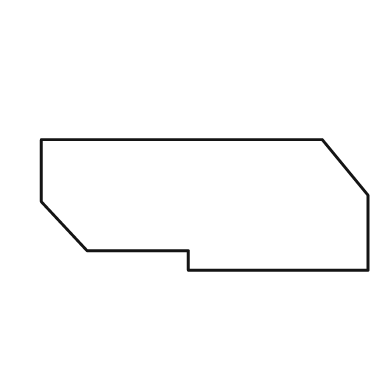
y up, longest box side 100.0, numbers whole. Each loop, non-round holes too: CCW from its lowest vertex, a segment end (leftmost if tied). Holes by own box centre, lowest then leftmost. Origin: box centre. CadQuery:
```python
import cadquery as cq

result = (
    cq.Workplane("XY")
    .moveTo(-5.0, -20.0)
    .lineTo(50.0, -20.0)
    .lineTo(50.0, 3.0)
    .lineTo(36.0, 20.0)
    .lineTo(-50.0, 20.0)
    .lineTo(-50.0, 1.0)
    .lineTo(-36.0, -14.0)
    .lineTo(-5.0, -14.0)
    .close()
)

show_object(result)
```